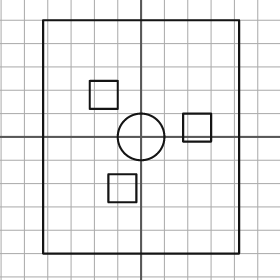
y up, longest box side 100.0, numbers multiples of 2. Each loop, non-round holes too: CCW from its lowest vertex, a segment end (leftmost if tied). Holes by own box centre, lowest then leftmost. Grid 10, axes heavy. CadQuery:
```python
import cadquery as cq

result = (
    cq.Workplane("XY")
    .moveTo(-42.0, -50.0)
    .lineTo(42.0, -50.0)
    .lineTo(42.0, 50.0)
    .lineTo(-42.0, 50.0)
    .close()
    .moveTo(-14.0, -28.0)
    .lineTo(-2.0, -28.0)
    .lineTo(-2.0, -16.0)
    .lineTo(-14.0, -16.0)
    .close()
    .moveTo(0.0, 0.0)
    .circle(10.0)
    .moveTo(18.0, -2.0)
    .lineTo(30.0, -2.0)
    .lineTo(30.0, 10.0)
    .lineTo(18.0, 10.0)
    .close()
    .moveTo(-22.0, 12.0)
    .lineTo(-10.0, 12.0)
    .lineTo(-10.0, 24.0)
    .lineTo(-22.0, 24.0)
    .close()
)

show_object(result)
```